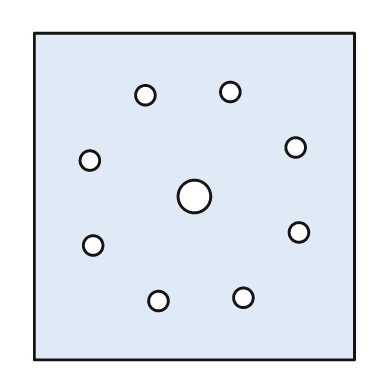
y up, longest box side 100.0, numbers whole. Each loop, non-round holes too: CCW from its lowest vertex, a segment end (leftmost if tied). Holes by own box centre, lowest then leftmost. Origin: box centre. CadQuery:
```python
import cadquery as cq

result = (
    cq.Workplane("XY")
    .moveTo(-49.0, -50.0)
    .lineTo(49.0, -50.0)
    .lineTo(49.0, 50.0)
    .lineTo(-49.0, 50.0)
    .close()
    .moveTo(-11.0, -32.0)
    .circle(3.0)
    .moveTo(15.0, -31.0)
    .circle(3.0)
    .moveTo(-31.0, -15.0)
    .circle(3.0)
    .moveTo(32.0, -11.0)
    .circle(3.0)
    .moveTo(0.0, 0.0)
    .circle(5.0)
    .moveTo(-32.0, 11.0)
    .circle(3.0)
    .moveTo(31.0, 15.0)
    .circle(3.0)
    .moveTo(-15.0, 31.0)
    .circle(3.0)
    .moveTo(11.0, 32.0)
    .circle(3.0)
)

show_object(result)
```